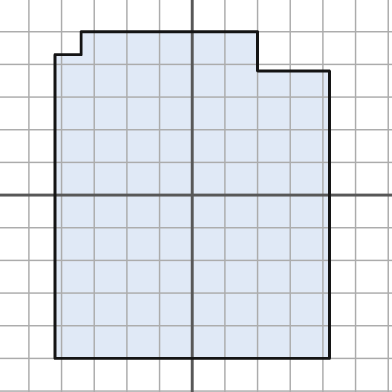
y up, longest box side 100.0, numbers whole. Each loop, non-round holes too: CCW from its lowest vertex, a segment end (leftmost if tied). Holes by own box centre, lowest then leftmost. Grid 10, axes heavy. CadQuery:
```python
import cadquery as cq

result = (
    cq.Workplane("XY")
    .moveTo(-42.0, -50.0)
    .lineTo(42.0, -50.0)
    .lineTo(42.0, 38.0)
    .lineTo(20.0, 38.0)
    .lineTo(20.0, 50.0)
    .lineTo(-34.0, 50.0)
    .lineTo(-34.0, 43.0)
    .lineTo(-42.0, 43.0)
    .close()
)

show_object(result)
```